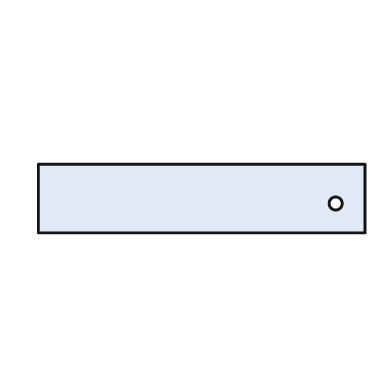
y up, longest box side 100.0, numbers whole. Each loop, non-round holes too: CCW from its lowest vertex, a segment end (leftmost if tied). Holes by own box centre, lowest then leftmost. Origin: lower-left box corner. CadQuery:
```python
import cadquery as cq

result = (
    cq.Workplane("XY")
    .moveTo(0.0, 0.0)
    .lineTo(100.0, 0.0)
    .lineTo(100.0, 21.0)
    .lineTo(0.0, 21.0)
    .close()
    .moveTo(91.0, 9.0)
    .circle(2.0)
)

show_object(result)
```